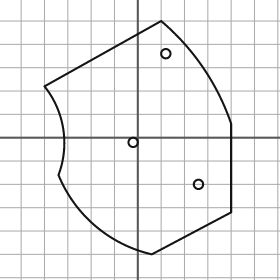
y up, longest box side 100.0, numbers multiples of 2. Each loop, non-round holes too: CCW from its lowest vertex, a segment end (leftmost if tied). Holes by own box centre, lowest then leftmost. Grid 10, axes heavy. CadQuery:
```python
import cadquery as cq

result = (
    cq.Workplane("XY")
    .moveTo(6.0, -50.0)
    .lineTo(40.0, -32.0)
    .lineTo(40.0, 6.0)
    .threePointArc((28.0, 30.0), (10.0, 50.0))
    .lineTo(-40.0, 22.0)
    .threePointArc((-32.0, 4.0), (-34.0, -16.0))
    .threePointArc((-18.0, -38.0), (6.0, -50.0))
    .close()
    .moveTo(26.0, -20.0)
    .circle(2.0)
    .moveTo(-2.0, -2.0)
    .circle(2.0)
    .moveTo(12.0, 36.0)
    .circle(2.0)
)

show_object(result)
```